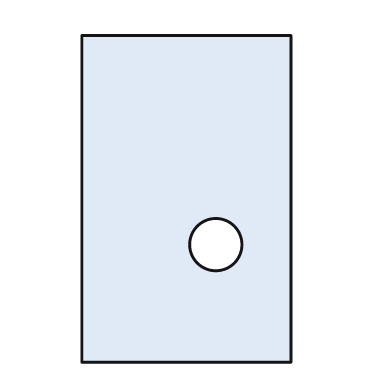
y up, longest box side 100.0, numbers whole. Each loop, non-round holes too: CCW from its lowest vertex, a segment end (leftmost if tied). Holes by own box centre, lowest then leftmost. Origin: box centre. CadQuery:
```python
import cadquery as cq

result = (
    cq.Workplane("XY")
    .moveTo(-32.0, -50.0)
    .lineTo(32.0, -50.0)
    .lineTo(32.0, 50.0)
    .lineTo(-32.0, 50.0)
    .close()
    .moveTo(9.0, -14.0)
    .circle(8.0)
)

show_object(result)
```